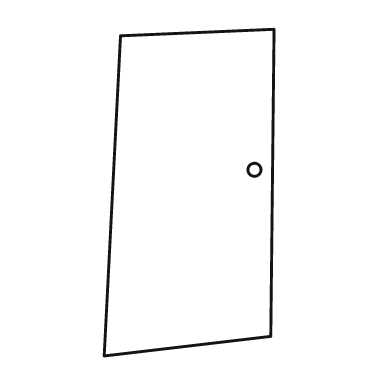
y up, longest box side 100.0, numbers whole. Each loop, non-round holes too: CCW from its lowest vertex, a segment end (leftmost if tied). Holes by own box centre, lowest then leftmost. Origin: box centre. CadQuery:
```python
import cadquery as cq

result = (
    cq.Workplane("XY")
    .moveTo(-26.0, -50.0)
    .lineTo(25.0, -44.0)
    .lineTo(26.0, 50.0)
    .lineTo(-21.0, 48.0)
    .close()
    .moveTo(20.0, 7.0)
    .circle(2.0)
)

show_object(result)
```